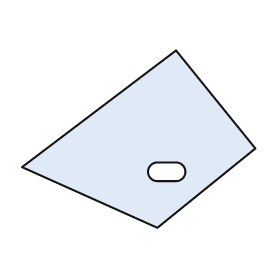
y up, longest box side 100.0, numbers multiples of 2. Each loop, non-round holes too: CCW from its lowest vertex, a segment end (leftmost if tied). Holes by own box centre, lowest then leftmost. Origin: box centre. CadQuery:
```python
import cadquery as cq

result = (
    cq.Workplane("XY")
    .moveTo(8.0, -38.0)
    .lineTo(50.0, -4.0)
    .lineTo(16.0, 38.0)
    .lineTo(-50.0, -12.0)
    .close()
    .moveTo(8.0, -18.0)
    .lineTo(16.0, -18.0)
    .threePointArc((20.0, -14.0), (16.0, -10.0))
    .lineTo(8.0, -10.0)
    .threePointArc((4.0, -14.0), (8.0, -18.0))
    .close()
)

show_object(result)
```